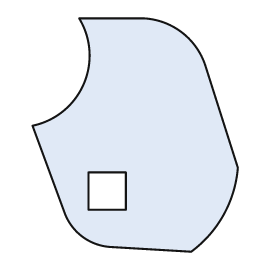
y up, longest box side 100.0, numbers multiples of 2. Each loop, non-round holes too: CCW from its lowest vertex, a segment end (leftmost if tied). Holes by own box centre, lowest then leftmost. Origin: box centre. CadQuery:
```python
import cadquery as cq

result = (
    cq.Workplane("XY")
    .moveTo(24.0, -50.0)
    .threePointArc((38.0, -34.0), (44.0, -14.0))
    .lineTo(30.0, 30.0)
    .threePointArc((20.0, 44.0), (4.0, 50.0))
    .lineTo(-24.0, 50.0)
    .threePointArc((-22.0, 22.0), (-44.0, 4.0))
    .lineTo(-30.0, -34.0)
    .threePointArc((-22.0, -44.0), (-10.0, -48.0))
    .close()
    .moveTo(-20.0, -32.0)
    .lineTo(-4.0, -32.0)
    .lineTo(-4.0, -16.0)
    .lineTo(-20.0, -16.0)
    .close()
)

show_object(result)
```